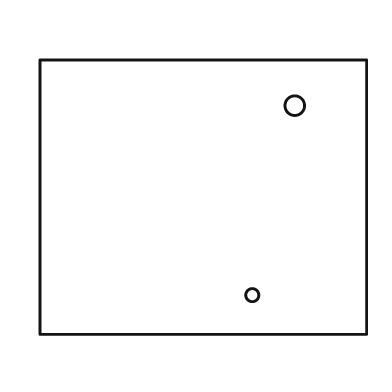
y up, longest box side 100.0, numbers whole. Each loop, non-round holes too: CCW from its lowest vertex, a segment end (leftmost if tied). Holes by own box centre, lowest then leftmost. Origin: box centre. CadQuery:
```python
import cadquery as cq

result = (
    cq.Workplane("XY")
    .moveTo(-50.0, -42.0)
    .lineTo(50.0, -42.0)
    .lineTo(50.0, 42.0)
    .lineTo(-50.0, 42.0)
    .close()
    .moveTo(15.0, -30.0)
    .circle(2.0)
    .moveTo(28.0, 28.0)
    .circle(3.0)
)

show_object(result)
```